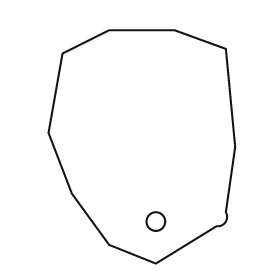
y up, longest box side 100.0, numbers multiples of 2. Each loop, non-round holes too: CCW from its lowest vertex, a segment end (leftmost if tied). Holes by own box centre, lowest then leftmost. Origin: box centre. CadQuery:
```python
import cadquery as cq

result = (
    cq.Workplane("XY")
    .moveTo(6.0, -50.0)
    .lineTo(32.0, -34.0)
    .threePointArc((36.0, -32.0), (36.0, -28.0))
    .lineTo(40.0, 0.0)
    .lineTo(36.0, 42.0)
    .lineTo(14.0, 50.0)
    .lineTo(-14.0, 50.0)
    .lineTo(-34.0, 40.0)
    .lineTo(-40.0, 6.0)
    .lineTo(-30.0, -20.0)
    .lineTo(-14.0, -42.0)
    .close()
    .moveTo(6.0, -32.0)
    .circle(4.0)
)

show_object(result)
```